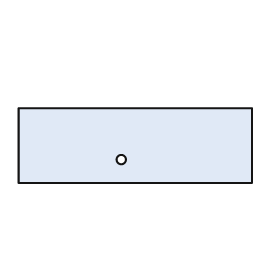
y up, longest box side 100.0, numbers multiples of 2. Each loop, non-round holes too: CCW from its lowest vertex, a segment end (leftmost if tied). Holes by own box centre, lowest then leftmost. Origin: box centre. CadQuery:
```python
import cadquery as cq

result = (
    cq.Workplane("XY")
    .moveTo(-50.0, -16.0)
    .lineTo(50.0, -16.0)
    .lineTo(50.0, 16.0)
    .lineTo(-50.0, 16.0)
    .close()
    .moveTo(-6.0, -6.0)
    .circle(2.0)
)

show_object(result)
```